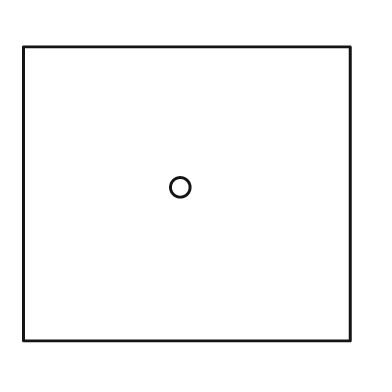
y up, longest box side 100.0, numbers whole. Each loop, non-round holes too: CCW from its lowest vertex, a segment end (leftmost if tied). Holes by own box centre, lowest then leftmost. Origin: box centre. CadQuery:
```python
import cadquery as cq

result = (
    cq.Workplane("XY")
    .moveTo(-50.0, -45.0)
    .lineTo(50.0, -45.0)
    .lineTo(50.0, 45.0)
    .lineTo(-50.0, 45.0)
    .close()
    .moveTo(-2.0, 2.0)
    .circle(3.0)
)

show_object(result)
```